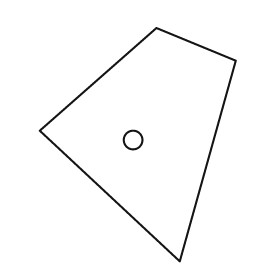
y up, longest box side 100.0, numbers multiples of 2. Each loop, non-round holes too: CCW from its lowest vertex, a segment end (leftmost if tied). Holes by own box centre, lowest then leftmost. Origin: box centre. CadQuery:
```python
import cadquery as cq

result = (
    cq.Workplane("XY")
    .moveTo(18.0, -50.0)
    .lineTo(42.0, 36.0)
    .lineTo(8.0, 50.0)
    .lineTo(-42.0, 6.0)
    .close()
    .moveTo(-2.0, 2.0)
    .circle(4.0)
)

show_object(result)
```